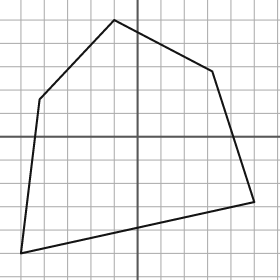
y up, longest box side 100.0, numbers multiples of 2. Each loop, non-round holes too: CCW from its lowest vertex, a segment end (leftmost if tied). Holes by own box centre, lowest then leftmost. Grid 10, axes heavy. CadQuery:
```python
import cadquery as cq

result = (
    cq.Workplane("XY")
    .moveTo(-50.0, -50.0)
    .lineTo(50.0, -28.0)
    .lineTo(32.0, 28.0)
    .lineTo(-10.0, 50.0)
    .lineTo(-42.0, 16.0)
    .close()
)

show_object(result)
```